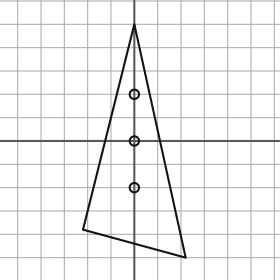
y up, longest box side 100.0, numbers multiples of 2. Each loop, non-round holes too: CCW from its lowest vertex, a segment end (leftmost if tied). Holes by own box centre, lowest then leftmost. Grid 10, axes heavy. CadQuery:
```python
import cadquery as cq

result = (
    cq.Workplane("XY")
    .moveTo(22.0, -50.0)
    .lineTo(0.0, 50.0)
    .lineTo(-22.0, -38.0)
    .close()
    .moveTo(0.0, -20.0)
    .circle(2.0)
    .moveTo(0.0, 0.0)
    .circle(2.0)
    .moveTo(0.0, 20.0)
    .circle(2.0)
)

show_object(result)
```